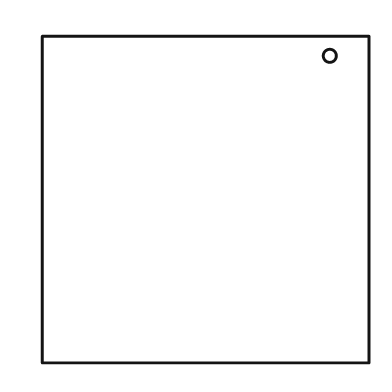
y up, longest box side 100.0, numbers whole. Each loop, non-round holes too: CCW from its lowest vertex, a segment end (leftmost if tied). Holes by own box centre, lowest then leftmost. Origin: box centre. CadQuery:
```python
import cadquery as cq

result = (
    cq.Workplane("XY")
    .moveTo(-50.0, -50.0)
    .lineTo(50.0, -50.0)
    .lineTo(50.0, 50.0)
    .lineTo(-50.0, 50.0)
    .close()
    .moveTo(38.0, 44.0)
    .circle(2.0)
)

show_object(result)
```